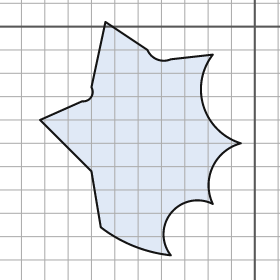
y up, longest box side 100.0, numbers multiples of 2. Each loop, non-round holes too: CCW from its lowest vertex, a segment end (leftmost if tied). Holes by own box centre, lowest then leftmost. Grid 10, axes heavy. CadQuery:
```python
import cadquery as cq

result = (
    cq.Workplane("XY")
    .moveTo(-36.0, -98.0)
    .threePointArc((-36.0, -80.0), (-18.0, -76.0))
    .threePointArc((-18.0, -60.0), (-6.0, -50.0))
    .threePointArc((-22.0, -34.0), (-18.0, -12.0))
    .lineTo(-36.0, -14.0)
    .threePointArc((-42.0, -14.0), (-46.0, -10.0))
    .lineTo(-64.0, 2.0)
    .lineTo(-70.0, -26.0)
    .threePointArc((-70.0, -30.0), (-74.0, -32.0))
    .lineTo(-92.0, -40.0)
    .lineTo(-70.0, -62.0)
    .lineTo(-66.0, -86.0)
    .threePointArc((-52.0, -94.0), (-36.0, -98.0))
    .close()
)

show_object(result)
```